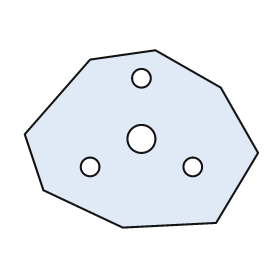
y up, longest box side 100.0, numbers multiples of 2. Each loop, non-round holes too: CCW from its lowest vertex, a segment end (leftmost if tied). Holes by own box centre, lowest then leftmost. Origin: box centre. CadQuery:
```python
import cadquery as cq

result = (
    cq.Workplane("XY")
    .moveTo(-8.0, -38.0)
    .lineTo(32.0, -36.0)
    .lineTo(50.0, -6.0)
    .lineTo(34.0, 22.0)
    .lineTo(6.0, 38.0)
    .lineTo(-22.0, 34.0)
    .lineTo(-50.0, 2.0)
    .lineTo(-42.0, -22.0)
    .close()
    .moveTo(-22.0, -12.0)
    .circle(4.0)
    .moveTo(22.0, -12.0)
    .circle(4.0)
    .moveTo(0.0, 0.0)
    .circle(6.0)
    .moveTo(0.0, 26.0)
    .circle(4.0)
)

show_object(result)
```